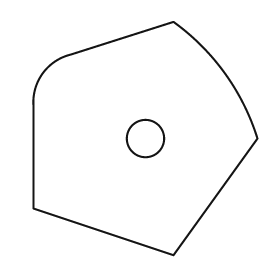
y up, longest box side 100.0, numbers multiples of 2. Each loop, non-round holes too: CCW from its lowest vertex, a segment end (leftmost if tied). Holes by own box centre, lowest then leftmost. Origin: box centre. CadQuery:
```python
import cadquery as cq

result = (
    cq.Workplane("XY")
    .moveTo(12.0, -50.0)
    .lineTo(48.0, 0.0)
    .threePointArc((34.0, 28.0), (12.0, 50.0))
    .lineTo(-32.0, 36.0)
    .threePointArc((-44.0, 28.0), (-48.0, 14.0))
    .lineTo(-48.0, -30.0)
    .close()
    .moveTo(0.0, 0.0)
    .circle(8.0)
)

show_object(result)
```